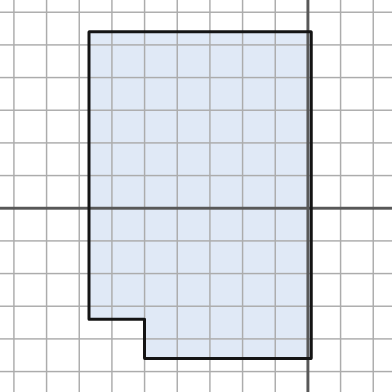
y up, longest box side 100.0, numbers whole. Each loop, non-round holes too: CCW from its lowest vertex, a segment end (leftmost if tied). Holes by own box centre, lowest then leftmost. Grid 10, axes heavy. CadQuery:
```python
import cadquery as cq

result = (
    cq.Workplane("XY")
    .moveTo(-50.0, -46.0)
    .lineTo(1.0, -46.0)
    .lineTo(1.0, 54.0)
    .lineTo(-67.0, 54.0)
    .lineTo(-67.0, -34.0)
    .lineTo(-50.0, -34.0)
    .close()
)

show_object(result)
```